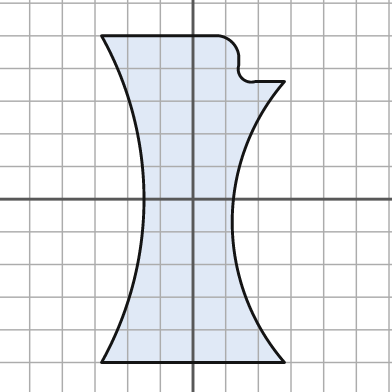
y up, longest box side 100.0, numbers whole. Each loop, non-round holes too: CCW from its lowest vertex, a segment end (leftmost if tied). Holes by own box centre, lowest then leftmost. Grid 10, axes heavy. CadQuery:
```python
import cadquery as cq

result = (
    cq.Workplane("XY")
    .moveTo(-28.0, -50.0)
    .lineTo(28.0, -50.0)
    .threePointArc((12.0, -7.0), (28.0, 36.0))
    .lineTo(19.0, 36.0)
    .threePointArc((15.0, 37.0), (14.0, 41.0))
    .lineTo(14.0, 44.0)
    .threePointArc((12.0, 48.0), (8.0, 50.0))
    .lineTo(-28.0, 50.0)
    .threePointArc((-15.0, 0.0), (-28.0, -50.0))
    .close()
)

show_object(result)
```